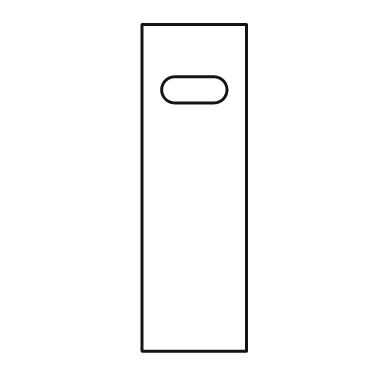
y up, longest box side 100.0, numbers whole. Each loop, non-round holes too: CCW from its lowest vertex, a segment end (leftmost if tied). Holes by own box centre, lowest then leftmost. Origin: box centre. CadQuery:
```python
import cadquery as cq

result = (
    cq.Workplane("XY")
    .moveTo(-16.0, -50.0)
    .lineTo(16.0, -50.0)
    .lineTo(16.0, 50.0)
    .lineTo(-16.0, 50.0)
    .close()
    .moveTo(-6.0, 26.0)
    .lineTo(6.0, 26.0)
    .threePointArc((10.0, 30.0), (6.0, 34.0))
    .lineTo(-6.0, 34.0)
    .threePointArc((-10.0, 30.0), (-6.0, 26.0))
    .close()
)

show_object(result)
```